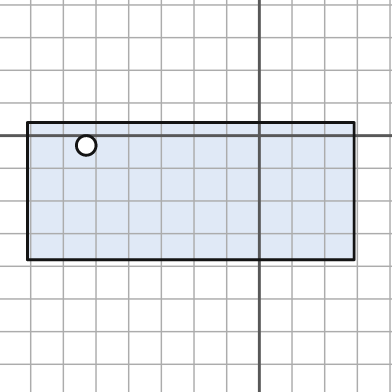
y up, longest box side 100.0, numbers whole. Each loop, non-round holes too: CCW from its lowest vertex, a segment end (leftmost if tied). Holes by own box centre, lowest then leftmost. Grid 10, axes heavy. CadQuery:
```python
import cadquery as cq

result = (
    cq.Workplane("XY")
    .moveTo(-71.0, -38.0)
    .lineTo(29.0, -38.0)
    .lineTo(29.0, 4.0)
    .lineTo(-71.0, 4.0)
    .close()
    .moveTo(-53.0, -3.0)
    .circle(3.0)
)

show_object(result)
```